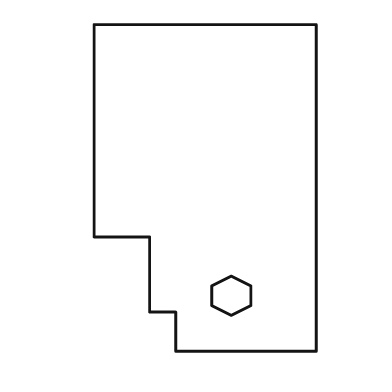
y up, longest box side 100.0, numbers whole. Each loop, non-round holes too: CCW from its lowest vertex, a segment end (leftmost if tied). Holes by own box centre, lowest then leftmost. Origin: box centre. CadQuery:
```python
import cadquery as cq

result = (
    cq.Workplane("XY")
    .moveTo(-9.0, -50.0)
    .lineTo(34.0, -50.0)
    .lineTo(34.0, 50.0)
    .lineTo(-34.0, 50.0)
    .lineTo(-34.0, -15.0)
    .lineTo(-17.0, -15.0)
    .lineTo(-17.0, -38.0)
    .lineTo(-9.0, -38.0)
    .close()
    .moveTo(8.0, -39.0)
    .lineTo(14.0, -36.0)
    .lineTo(14.0, -30.0)
    .lineTo(8.0, -27.0)
    .lineTo(2.0, -30.0)
    .lineTo(2.0, -36.0)
    .close()
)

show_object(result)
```